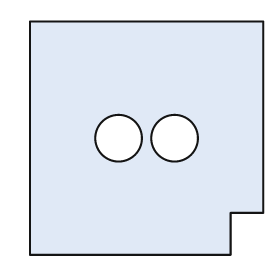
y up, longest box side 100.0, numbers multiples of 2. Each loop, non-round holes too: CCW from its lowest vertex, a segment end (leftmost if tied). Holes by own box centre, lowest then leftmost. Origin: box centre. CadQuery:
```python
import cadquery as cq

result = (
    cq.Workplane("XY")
    .moveTo(-50.0, -50.0)
    .lineTo(36.0, -50.0)
    .lineTo(36.0, -32.0)
    .lineTo(50.0, -32.0)
    .lineTo(50.0, 50.0)
    .lineTo(-50.0, 50.0)
    .close()
    .moveTo(-12.0, 0.0)
    .circle(10.0)
    .moveTo(12.0, 0.0)
    .circle(10.0)
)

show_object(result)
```